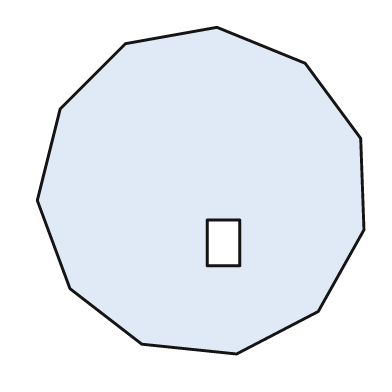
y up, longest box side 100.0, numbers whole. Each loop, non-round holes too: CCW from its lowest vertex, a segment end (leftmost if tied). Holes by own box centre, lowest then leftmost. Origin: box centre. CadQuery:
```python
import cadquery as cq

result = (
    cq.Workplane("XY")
    .moveTo(11.0, -50.0)
    .lineTo(36.0, -37.0)
    .lineTo(50.0, -12.0)
    .lineTo(49.0, 16.0)
    .lineTo(32.0, 39.0)
    .lineTo(5.0, 50.0)
    .lineTo(-23.0, 45.0)
    .lineTo(-43.0, 25.0)
    .lineTo(-50.0, -3.0)
    .lineTo(-40.0, -30.0)
    .lineTo(-18.0, -47.0)
    .close()
    .moveTo(2.0, -23.0)
    .lineTo(12.0, -23.0)
    .lineTo(12.0, -9.0)
    .lineTo(2.0, -9.0)
    .close()
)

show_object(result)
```